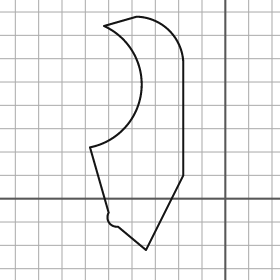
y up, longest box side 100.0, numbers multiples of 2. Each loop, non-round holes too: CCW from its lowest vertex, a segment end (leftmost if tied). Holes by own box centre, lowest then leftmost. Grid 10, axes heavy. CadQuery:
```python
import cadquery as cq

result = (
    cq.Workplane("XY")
    .moveTo(-34.0, -22.0)
    .lineTo(-18.0, 10.0)
    .lineTo(-18.0, 58.0)
    .threePointArc((-24.0, 72.0), (-38.0, 78.0))
    .lineTo(-52.0, 74.0)
    .threePointArc((-36.0, 46.0), (-58.0, 22.0))
    .lineTo(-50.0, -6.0)
    .threePointArc((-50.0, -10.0), (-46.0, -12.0))
    .close()
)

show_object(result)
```